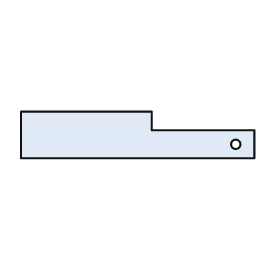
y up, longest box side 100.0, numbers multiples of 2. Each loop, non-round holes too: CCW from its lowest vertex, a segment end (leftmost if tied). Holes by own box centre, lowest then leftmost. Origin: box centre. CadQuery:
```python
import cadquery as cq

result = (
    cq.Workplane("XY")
    .moveTo(-50.0, -10.0)
    .lineTo(50.0, -10.0)
    .lineTo(50.0, 2.0)
    .lineTo(6.0, 2.0)
    .lineTo(6.0, 10.0)
    .lineTo(-50.0, 10.0)
    .close()
    .moveTo(42.0, -4.0)
    .circle(2.0)
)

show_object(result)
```